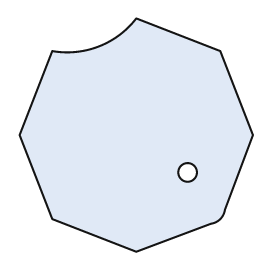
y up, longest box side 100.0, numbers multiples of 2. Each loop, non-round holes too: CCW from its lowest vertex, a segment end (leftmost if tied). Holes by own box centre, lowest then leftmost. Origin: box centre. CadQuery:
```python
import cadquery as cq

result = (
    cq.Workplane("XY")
    .moveTo(0.0, -50.0)
    .lineTo(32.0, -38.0)
    .threePointArc((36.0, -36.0), (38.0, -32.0))
    .lineTo(50.0, 0.0)
    .lineTo(36.0, 36.0)
    .lineTo(0.0, 50.0)
    .threePointArc((-16.0, 38.0), (-36.0, 36.0))
    .lineTo(-50.0, 0.0)
    .lineTo(-36.0, -36.0)
    .close()
    .moveTo(22.0, -16.0)
    .circle(4.0)
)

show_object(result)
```